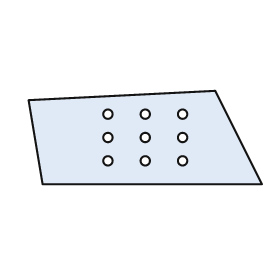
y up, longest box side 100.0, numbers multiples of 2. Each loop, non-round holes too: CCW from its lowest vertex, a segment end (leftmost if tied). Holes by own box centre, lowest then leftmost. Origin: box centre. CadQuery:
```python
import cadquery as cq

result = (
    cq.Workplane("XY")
    .moveTo(-44.0, -20.0)
    .lineTo(50.0, -20.0)
    .lineTo(30.0, 20.0)
    .lineTo(-50.0, 16.0)
    .close()
    .moveTo(-16.0, -10.0)
    .circle(2.0)
    .moveTo(0.0, -10.0)
    .circle(2.0)
    .moveTo(16.0, -10.0)
    .circle(2.0)
    .moveTo(-16.0, 0.0)
    .circle(2.0)
    .moveTo(0.0, 0.0)
    .circle(2.0)
    .moveTo(16.0, 0.0)
    .circle(2.0)
    .moveTo(-16.0, 10.0)
    .circle(2.0)
    .moveTo(0.0, 10.0)
    .circle(2.0)
    .moveTo(16.0, 10.0)
    .circle(2.0)
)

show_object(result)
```